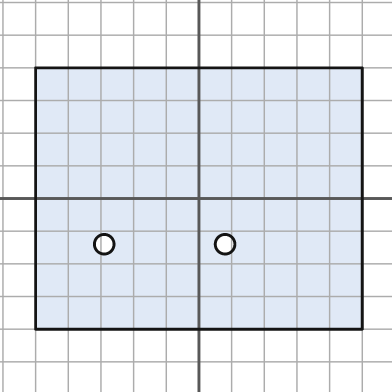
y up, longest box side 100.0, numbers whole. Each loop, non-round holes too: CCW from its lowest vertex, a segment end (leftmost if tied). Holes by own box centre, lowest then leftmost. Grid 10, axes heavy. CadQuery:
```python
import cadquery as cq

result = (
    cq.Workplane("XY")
    .moveTo(-50.0, -40.0)
    .lineTo(50.0, -40.0)
    .lineTo(50.0, 40.0)
    .lineTo(-50.0, 40.0)
    .close()
    .moveTo(-29.0, -14.0)
    .circle(3.0)
    .moveTo(8.0, -14.0)
    .circle(3.0)
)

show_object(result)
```